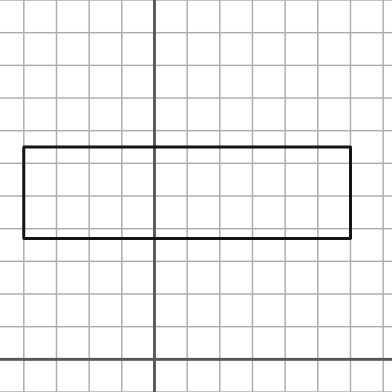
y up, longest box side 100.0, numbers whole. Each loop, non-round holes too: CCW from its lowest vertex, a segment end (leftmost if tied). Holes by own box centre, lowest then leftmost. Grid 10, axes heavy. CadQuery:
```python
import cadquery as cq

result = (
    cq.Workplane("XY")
    .moveTo(-40.0, 37.0)
    .lineTo(60.0, 37.0)
    .lineTo(60.0, 65.0)
    .lineTo(-40.0, 65.0)
    .close()
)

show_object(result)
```